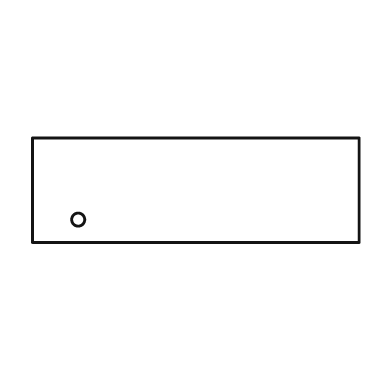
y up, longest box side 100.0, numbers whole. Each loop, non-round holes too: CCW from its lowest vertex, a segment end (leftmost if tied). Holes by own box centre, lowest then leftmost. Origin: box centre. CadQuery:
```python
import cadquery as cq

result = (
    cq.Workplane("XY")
    .moveTo(-50.0, -16.0)
    .lineTo(50.0, -16.0)
    .lineTo(50.0, 16.0)
    .lineTo(-50.0, 16.0)
    .close()
    .moveTo(-36.0, -9.0)
    .circle(2.0)
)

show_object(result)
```